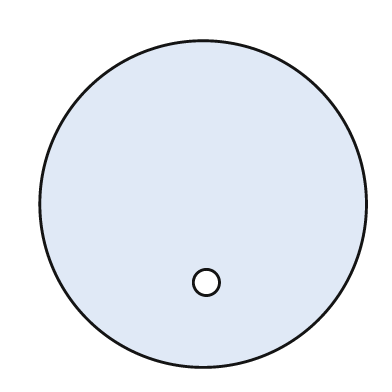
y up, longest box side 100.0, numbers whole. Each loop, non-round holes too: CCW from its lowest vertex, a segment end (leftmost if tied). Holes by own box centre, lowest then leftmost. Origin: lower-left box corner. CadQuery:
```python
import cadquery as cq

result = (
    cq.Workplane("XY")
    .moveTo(50.0, 50.0)
    .circle(50.0)
    .moveTo(51.0, 26.0)
    .circle(4.0)
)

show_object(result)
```